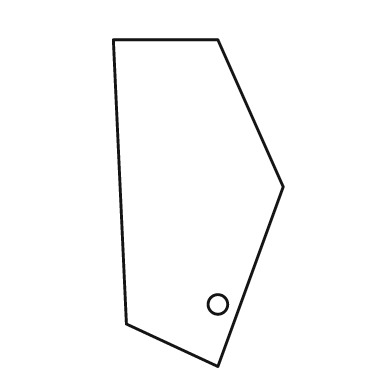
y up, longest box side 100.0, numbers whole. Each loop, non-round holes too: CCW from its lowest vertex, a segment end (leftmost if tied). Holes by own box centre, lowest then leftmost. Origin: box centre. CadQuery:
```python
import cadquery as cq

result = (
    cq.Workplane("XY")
    .moveTo(6.0, -50.0)
    .lineTo(26.0, 5.0)
    .lineTo(6.0, 50.0)
    .lineTo(-26.0, 50.0)
    .lineTo(-22.0, -37.0)
    .close()
    .moveTo(6.0, -31.0)
    .circle(3.0)
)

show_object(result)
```